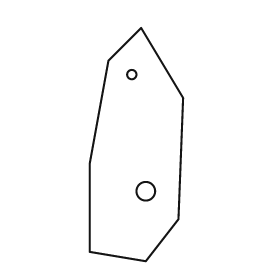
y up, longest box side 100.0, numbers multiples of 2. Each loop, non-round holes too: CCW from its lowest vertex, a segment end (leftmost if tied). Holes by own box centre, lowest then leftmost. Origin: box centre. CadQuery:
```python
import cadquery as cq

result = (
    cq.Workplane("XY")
    .moveTo(4.0, -50.0)
    .lineTo(18.0, -32.0)
    .lineTo(20.0, 20.0)
    .lineTo(2.0, 50.0)
    .lineTo(-12.0, 36.0)
    .lineTo(-20.0, -8.0)
    .lineTo(-20.0, -46.0)
    .close()
    .moveTo(4.0, -20.0)
    .circle(4.0)
    .moveTo(-2.0, 30.0)
    .circle(2.0)
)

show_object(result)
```